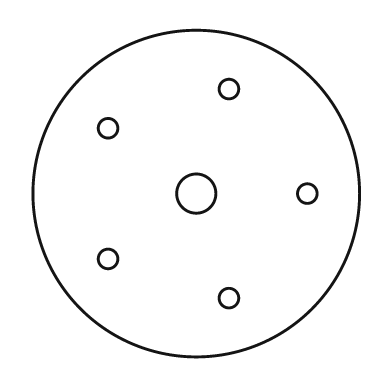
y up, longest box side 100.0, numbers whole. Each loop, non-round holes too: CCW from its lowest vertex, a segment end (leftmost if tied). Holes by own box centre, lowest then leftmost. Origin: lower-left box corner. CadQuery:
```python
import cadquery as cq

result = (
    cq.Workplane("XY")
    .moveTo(50.0, 50.0)
    .circle(50.0)
    .moveTo(60.0, 18.0)
    .circle(3.0)
    .moveTo(23.0, 30.0)
    .circle(3.0)
    .moveTo(50.0, 50.0)
    .circle(6.0)
    .moveTo(84.0, 50.0)
    .circle(3.0)
    .moveTo(23.0, 70.0)
    .circle(3.0)
    .moveTo(60.0, 82.0)
    .circle(3.0)
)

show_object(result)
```